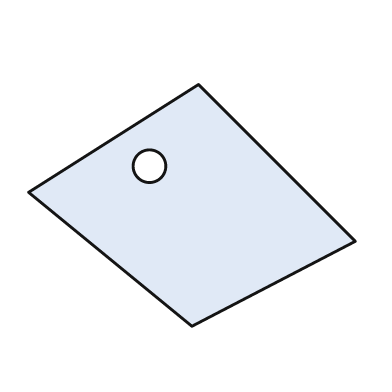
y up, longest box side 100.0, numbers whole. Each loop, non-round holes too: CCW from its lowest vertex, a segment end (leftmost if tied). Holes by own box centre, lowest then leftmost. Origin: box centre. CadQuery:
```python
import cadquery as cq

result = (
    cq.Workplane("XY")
    .moveTo(0.0, -37.0)
    .lineTo(50.0, -11.0)
    .lineTo(2.0, 37.0)
    .lineTo(-50.0, 4.0)
    .close()
    .moveTo(-13.0, 12.0)
    .circle(5.0)
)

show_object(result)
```